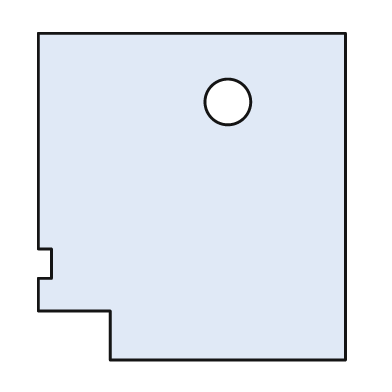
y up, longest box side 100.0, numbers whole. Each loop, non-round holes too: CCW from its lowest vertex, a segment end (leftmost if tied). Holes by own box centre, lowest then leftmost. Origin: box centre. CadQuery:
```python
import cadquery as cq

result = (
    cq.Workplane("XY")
    .moveTo(-25.0, -50.0)
    .lineTo(47.0, -50.0)
    .lineTo(47.0, 50.0)
    .lineTo(-47.0, 50.0)
    .lineTo(-47.0, -16.0)
    .lineTo(-43.0, -16.0)
    .lineTo(-43.0, -25.0)
    .lineTo(-47.0, -25.0)
    .lineTo(-47.0, -35.0)
    .lineTo(-25.0, -35.0)
    .close()
    .moveTo(11.0, 29.0)
    .circle(7.0)
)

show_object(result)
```